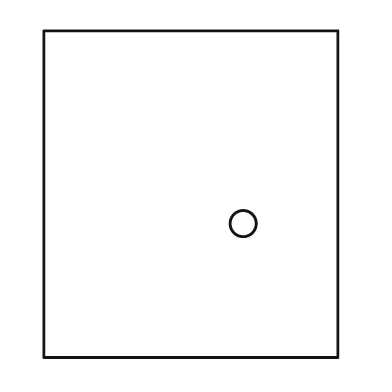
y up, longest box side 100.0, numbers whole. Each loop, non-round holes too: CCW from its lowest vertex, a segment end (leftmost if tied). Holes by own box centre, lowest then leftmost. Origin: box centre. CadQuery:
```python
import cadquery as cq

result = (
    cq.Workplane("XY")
    .moveTo(-45.0, -50.0)
    .lineTo(45.0, -50.0)
    .lineTo(45.0, 50.0)
    .lineTo(-45.0, 50.0)
    .close()
    .moveTo(16.0, -9.0)
    .circle(4.0)
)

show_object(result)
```